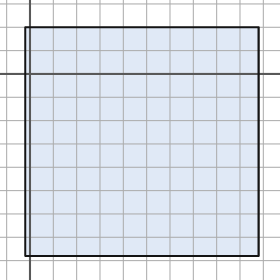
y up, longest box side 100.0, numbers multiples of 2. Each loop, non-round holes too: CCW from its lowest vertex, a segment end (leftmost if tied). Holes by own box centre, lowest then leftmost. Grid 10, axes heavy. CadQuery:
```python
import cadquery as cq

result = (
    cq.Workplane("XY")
    .moveTo(-2.0, -78.0)
    .lineTo(98.0, -78.0)
    .lineTo(98.0, 20.0)
    .lineTo(-2.0, 20.0)
    .close()
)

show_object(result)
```